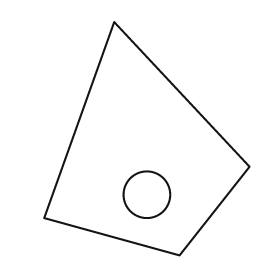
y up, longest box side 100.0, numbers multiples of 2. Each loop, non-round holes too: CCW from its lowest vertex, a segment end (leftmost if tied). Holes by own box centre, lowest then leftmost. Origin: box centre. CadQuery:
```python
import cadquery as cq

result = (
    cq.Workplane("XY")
    .moveTo(14.0, -50.0)
    .lineTo(44.0, -12.0)
    .lineTo(-14.0, 50.0)
    .lineTo(-44.0, -34.0)
    .close()
    .moveTo(0.0, -24.0)
    .circle(10.0)
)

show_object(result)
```